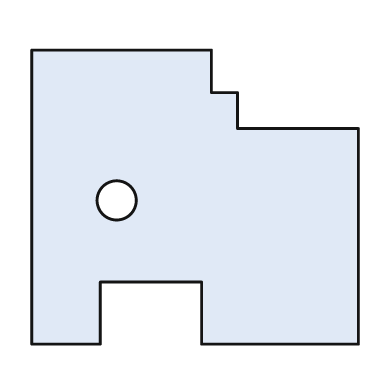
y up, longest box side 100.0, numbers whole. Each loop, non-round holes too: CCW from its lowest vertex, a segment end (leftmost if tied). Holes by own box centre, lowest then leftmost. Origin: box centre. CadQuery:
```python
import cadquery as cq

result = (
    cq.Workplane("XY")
    .moveTo(-50.0, -45.0)
    .lineTo(-29.0, -45.0)
    .lineTo(-29.0, -26.0)
    .lineTo(2.0, -26.0)
    .lineTo(2.0, -45.0)
    .lineTo(50.0, -45.0)
    .lineTo(50.0, 21.0)
    .lineTo(13.0, 21.0)
    .lineTo(13.0, 32.0)
    .lineTo(5.0, 32.0)
    .lineTo(5.0, 45.0)
    .lineTo(-50.0, 45.0)
    .close()
    .moveTo(-24.0, -1.0)
    .circle(6.0)
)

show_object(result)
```